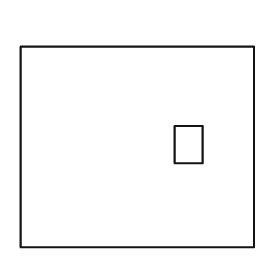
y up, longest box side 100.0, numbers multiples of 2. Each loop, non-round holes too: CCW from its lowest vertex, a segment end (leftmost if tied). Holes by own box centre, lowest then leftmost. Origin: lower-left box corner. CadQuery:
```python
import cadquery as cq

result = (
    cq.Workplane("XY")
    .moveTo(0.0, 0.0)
    .lineTo(100.0, 0.0)
    .lineTo(100.0, 86.0)
    .lineTo(0.0, 86.0)
    .close()
    .moveTo(66.0, 36.0)
    .lineTo(78.0, 36.0)
    .lineTo(78.0, 52.0)
    .lineTo(66.0, 52.0)
    .close()
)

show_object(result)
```